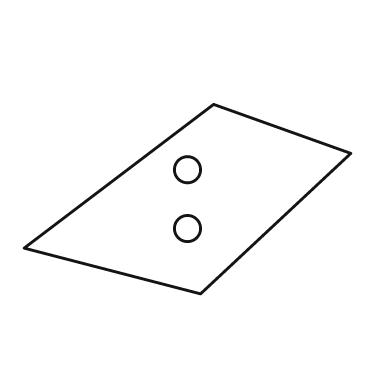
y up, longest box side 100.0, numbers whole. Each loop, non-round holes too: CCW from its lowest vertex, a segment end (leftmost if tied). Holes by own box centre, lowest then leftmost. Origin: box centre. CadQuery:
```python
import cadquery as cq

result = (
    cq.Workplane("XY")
    .moveTo(4.0, -29.0)
    .lineTo(50.0, 14.0)
    .lineTo(8.0, 29.0)
    .lineTo(-50.0, -15.0)
    .close()
    .moveTo(0.0, -9.0)
    .circle(4.0)
    .moveTo(0.0, 9.0)
    .circle(4.0)
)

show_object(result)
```